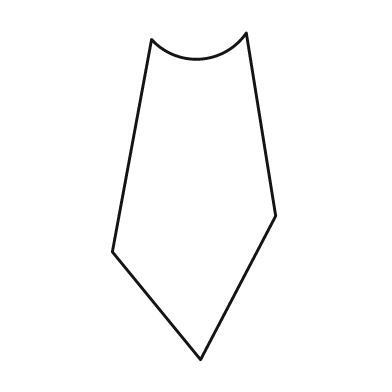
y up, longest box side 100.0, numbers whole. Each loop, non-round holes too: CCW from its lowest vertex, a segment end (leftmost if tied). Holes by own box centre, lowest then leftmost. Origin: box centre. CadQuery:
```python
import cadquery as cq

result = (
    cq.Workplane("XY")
    .moveTo(2.0, -50.0)
    .lineTo(25.0, -6.0)
    .lineTo(16.0, 50.0)
    .threePointArc((2.0, 42.0), (-13.0, 48.0))
    .lineTo(-25.0, -17.0)
    .close()
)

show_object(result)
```